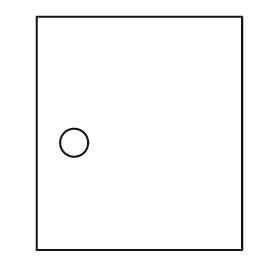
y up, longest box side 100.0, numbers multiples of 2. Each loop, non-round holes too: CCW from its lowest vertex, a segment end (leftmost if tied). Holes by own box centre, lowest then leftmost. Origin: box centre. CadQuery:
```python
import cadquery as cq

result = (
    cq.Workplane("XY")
    .moveTo(-44.0, -50.0)
    .lineTo(44.0, -50.0)
    .lineTo(44.0, 50.0)
    .lineTo(-44.0, 50.0)
    .close()
    .moveTo(-28.0, -4.0)
    .circle(6.0)
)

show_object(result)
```